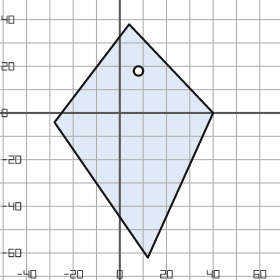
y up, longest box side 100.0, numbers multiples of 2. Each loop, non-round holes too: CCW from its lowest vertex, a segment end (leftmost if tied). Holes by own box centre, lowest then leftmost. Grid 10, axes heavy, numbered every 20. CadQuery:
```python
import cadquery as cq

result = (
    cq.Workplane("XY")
    .moveTo(12.0, -62.0)
    .lineTo(40.0, 0.0)
    .lineTo(4.0, 38.0)
    .lineTo(-28.0, -4.0)
    .close()
    .moveTo(8.0, 18.0)
    .circle(2.0)
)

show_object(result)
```